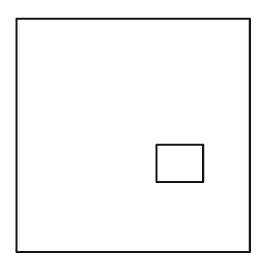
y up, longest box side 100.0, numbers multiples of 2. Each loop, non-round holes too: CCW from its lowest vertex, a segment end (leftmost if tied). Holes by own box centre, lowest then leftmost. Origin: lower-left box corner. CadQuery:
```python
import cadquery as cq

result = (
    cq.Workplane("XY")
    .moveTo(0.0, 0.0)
    .lineTo(100.0, 0.0)
    .lineTo(100.0, 100.0)
    .lineTo(0.0, 100.0)
    .close()
    .moveTo(60.0, 30.0)
    .lineTo(80.0, 30.0)
    .lineTo(80.0, 46.0)
    .lineTo(60.0, 46.0)
    .close()
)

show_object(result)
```